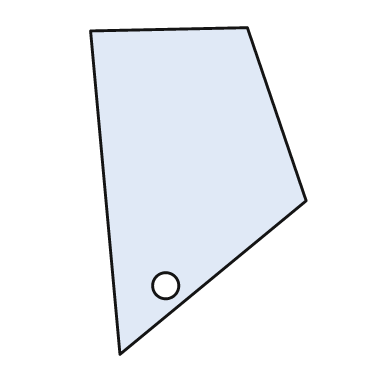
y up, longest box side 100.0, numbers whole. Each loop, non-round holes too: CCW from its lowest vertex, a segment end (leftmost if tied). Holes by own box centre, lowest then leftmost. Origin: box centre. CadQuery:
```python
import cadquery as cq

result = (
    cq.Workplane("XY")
    .moveTo(-24.0, -50.0)
    .lineTo(33.0, -3.0)
    .lineTo(15.0, 50.0)
    .lineTo(-33.0, 49.0)
    .close()
    .moveTo(-10.0, -29.0)
    .circle(4.0)
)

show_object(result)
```